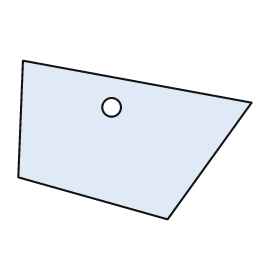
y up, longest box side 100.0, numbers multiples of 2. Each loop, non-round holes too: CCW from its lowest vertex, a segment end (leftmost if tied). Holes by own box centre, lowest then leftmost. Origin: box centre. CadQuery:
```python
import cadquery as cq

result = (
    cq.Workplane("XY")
    .moveTo(14.0, -34.0)
    .lineTo(50.0, 16.0)
    .lineTo(-48.0, 34.0)
    .lineTo(-50.0, -16.0)
    .close()
    .moveTo(-10.0, 14.0)
    .circle(4.0)
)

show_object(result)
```